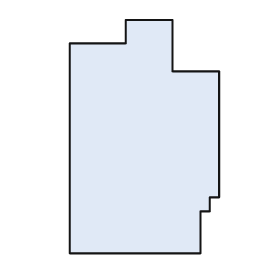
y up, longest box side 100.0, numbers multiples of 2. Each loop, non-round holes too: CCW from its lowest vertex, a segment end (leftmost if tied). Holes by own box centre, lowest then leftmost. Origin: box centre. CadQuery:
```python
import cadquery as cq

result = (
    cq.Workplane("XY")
    .moveTo(-32.0, -50.0)
    .lineTo(24.0, -50.0)
    .lineTo(24.0, -32.0)
    .lineTo(28.0, -32.0)
    .lineTo(28.0, -26.0)
    .lineTo(32.0, -26.0)
    .lineTo(32.0, 28.0)
    .lineTo(12.0, 28.0)
    .lineTo(12.0, 50.0)
    .lineTo(-8.0, 50.0)
    .lineTo(-8.0, 40.0)
    .lineTo(-32.0, 40.0)
    .close()
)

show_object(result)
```